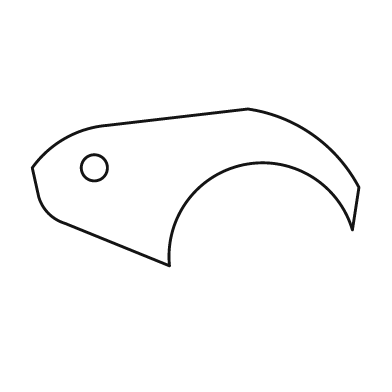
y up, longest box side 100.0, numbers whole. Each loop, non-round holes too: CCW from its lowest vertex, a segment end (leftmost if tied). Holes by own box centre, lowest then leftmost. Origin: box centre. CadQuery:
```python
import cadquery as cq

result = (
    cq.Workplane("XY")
    .moveTo(-8.0, -24.0)
    .threePointArc((15.0, 7.0), (48.0, -13.0))
    .lineTo(50.0, 0.0)
    .threePointArc((36.0, 16.0), (16.0, 24.0))
    .lineTo(-27.0, 19.0)
    .threePointArc((-40.0, 15.0), (-50.0, 6.0))
    .lineTo(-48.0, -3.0)
    .threePointArc((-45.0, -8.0), (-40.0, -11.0))
    .close()
    .moveTo(-31.0, 6.0)
    .circle(4.0)
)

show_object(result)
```